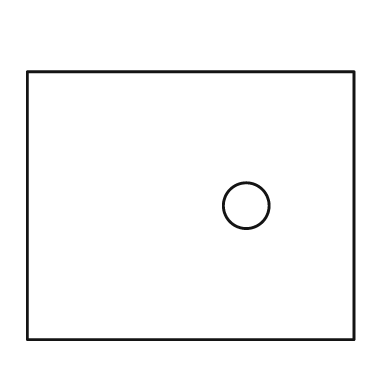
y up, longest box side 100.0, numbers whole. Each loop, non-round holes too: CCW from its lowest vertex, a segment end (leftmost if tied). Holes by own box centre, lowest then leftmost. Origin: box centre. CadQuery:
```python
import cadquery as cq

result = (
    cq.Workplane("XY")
    .moveTo(-50.0, -41.0)
    .lineTo(50.0, -41.0)
    .lineTo(50.0, 41.0)
    .lineTo(-50.0, 41.0)
    .close()
    .moveTo(17.0, 0.0)
    .circle(7.0)
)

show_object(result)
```